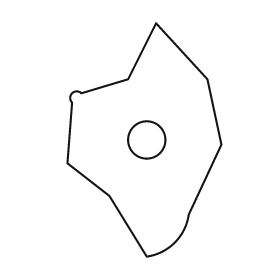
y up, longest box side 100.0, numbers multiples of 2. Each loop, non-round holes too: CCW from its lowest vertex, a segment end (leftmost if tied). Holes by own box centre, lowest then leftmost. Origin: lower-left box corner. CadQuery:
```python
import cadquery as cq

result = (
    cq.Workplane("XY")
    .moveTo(34.0, 0.0)
    .threePointArc((46.0, 6.0), (52.0, 18.0))
    .lineTo(66.0, 48.0)
    .lineTo(60.0, 76.0)
    .lineTo(38.0, 100.0)
    .lineTo(26.0, 76.0)
    .lineTo(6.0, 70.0)
    .threePointArc((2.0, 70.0), (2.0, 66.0))
    .lineTo(0.0, 40.0)
    .lineTo(18.0, 26.0)
    .close()
    .moveTo(34.0, 50.0)
    .circle(8.0)
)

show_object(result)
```